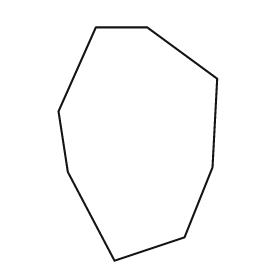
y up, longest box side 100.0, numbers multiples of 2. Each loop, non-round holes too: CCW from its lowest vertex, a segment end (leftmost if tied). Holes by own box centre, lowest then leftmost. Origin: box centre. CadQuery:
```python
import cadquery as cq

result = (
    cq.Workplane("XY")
    .moveTo(-10.0, -50.0)
    .lineTo(20.0, -40.0)
    .lineTo(32.0, -10.0)
    .lineTo(34.0, 28.0)
    .lineTo(4.0, 50.0)
    .lineTo(-18.0, 50.0)
    .lineTo(-34.0, 14.0)
    .lineTo(-30.0, -12.0)
    .close()
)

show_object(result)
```